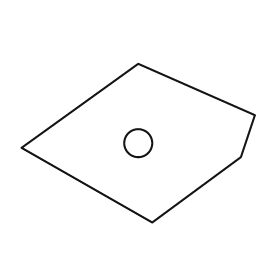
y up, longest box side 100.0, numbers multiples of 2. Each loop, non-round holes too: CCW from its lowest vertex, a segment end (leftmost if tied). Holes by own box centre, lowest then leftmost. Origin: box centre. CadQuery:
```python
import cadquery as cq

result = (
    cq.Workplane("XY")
    .moveTo(6.0, -34.0)
    .lineTo(44.0, -6.0)
    .lineTo(50.0, 12.0)
    .lineTo(0.0, 34.0)
    .lineTo(-50.0, -2.0)
    .close()
    .moveTo(0.0, 0.0)
    .circle(6.0)
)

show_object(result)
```